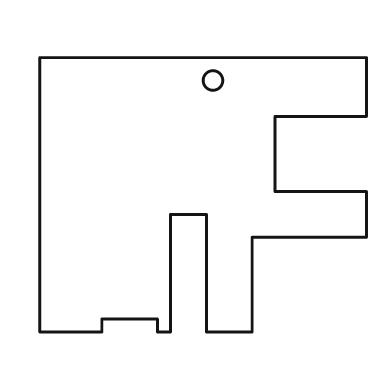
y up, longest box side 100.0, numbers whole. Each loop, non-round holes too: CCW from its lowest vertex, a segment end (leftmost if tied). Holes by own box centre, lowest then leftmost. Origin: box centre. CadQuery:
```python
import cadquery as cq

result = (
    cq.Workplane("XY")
    .moveTo(-50.0, -42.0)
    .lineTo(-31.0, -42.0)
    .lineTo(-31.0, -38.0)
    .lineTo(-14.0, -38.0)
    .lineTo(-14.0, -42.0)
    .lineTo(-10.0, -42.0)
    .lineTo(-10.0, -6.0)
    .lineTo(1.0, -6.0)
    .lineTo(1.0, -42.0)
    .lineTo(15.0, -42.0)
    .lineTo(15.0, -13.0)
    .lineTo(50.0, -13.0)
    .lineTo(50.0, 1.0)
    .lineTo(22.0, 1.0)
    .lineTo(22.0, 24.0)
    .lineTo(50.0, 24.0)
    .lineTo(50.0, 42.0)
    .lineTo(-50.0, 42.0)
    .close()
    .moveTo(3.0, 35.0)
    .circle(3.0)
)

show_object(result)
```